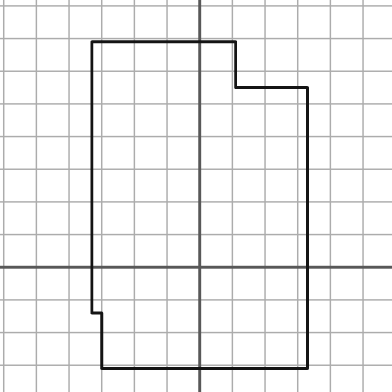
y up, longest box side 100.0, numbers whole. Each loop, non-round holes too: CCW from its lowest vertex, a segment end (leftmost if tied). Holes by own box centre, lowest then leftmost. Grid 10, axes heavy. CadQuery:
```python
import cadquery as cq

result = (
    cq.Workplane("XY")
    .moveTo(-30.0, -31.0)
    .lineTo(33.0, -31.0)
    .lineTo(33.0, 55.0)
    .lineTo(11.0, 55.0)
    .lineTo(11.0, 69.0)
    .lineTo(-33.0, 69.0)
    .lineTo(-33.0, -14.0)
    .lineTo(-30.0, -14.0)
    .close()
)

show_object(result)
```